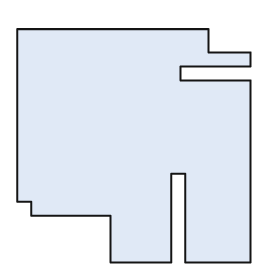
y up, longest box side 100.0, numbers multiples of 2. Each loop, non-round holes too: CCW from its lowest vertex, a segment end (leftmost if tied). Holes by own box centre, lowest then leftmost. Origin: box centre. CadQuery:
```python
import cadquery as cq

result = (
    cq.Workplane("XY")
    .moveTo(-10.0, -50.0)
    .lineTo(16.0, -50.0)
    .lineTo(16.0, -12.0)
    .lineTo(22.0, -12.0)
    .lineTo(22.0, -50.0)
    .lineTo(50.0, -50.0)
    .lineTo(50.0, 28.0)
    .lineTo(20.0, 28.0)
    .lineTo(20.0, 34.0)
    .lineTo(50.0, 34.0)
    .lineTo(50.0, 40.0)
    .lineTo(32.0, 40.0)
    .lineTo(32.0, 50.0)
    .lineTo(-50.0, 50.0)
    .lineTo(-50.0, -24.0)
    .lineTo(-44.0, -24.0)
    .lineTo(-44.0, -30.0)
    .lineTo(-10.0, -30.0)
    .close()
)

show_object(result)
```